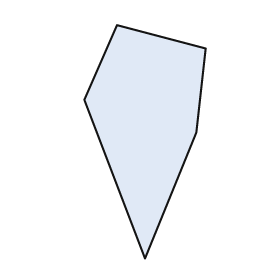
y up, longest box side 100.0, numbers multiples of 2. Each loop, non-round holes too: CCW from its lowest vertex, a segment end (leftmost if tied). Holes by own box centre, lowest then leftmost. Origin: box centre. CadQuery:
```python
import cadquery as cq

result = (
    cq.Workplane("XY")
    .moveTo(0.0, -50.0)
    .lineTo(22.0, 4.0)
    .lineTo(26.0, 40.0)
    .lineTo(-12.0, 50.0)
    .lineTo(-26.0, 18.0)
    .close()
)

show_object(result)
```